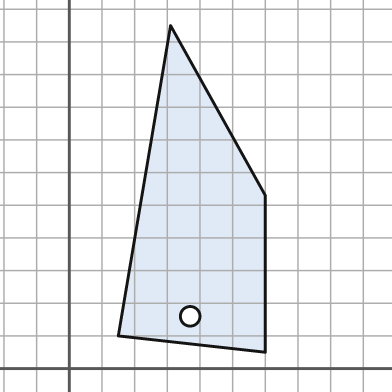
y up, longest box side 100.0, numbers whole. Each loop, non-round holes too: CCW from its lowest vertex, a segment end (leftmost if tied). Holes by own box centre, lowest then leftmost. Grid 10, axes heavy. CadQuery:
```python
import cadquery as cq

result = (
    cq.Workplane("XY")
    .moveTo(60.0, 5.0)
    .lineTo(60.0, 53.0)
    .lineTo(31.0, 105.0)
    .lineTo(15.0, 10.0)
    .close()
    .moveTo(37.0, 16.0)
    .circle(3.0)
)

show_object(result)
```